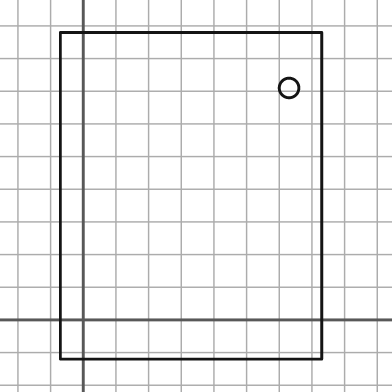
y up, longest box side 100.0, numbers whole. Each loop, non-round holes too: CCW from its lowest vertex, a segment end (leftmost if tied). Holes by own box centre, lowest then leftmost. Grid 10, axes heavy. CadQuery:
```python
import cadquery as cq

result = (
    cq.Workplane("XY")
    .moveTo(-7.0, -12.0)
    .lineTo(73.0, -12.0)
    .lineTo(73.0, 88.0)
    .lineTo(-7.0, 88.0)
    .close()
    .moveTo(63.0, 71.0)
    .circle(3.0)
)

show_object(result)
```